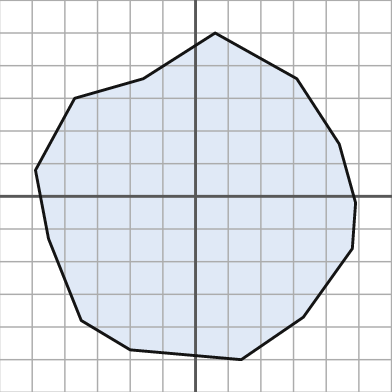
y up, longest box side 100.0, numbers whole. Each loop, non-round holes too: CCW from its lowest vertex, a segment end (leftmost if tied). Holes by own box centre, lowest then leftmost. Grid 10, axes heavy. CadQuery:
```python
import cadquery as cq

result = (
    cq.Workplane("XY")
    .moveTo(14.0, -50.0)
    .lineTo(33.0, -37.0)
    .lineTo(48.0, -16.0)
    .lineTo(49.0, -2.0)
    .lineTo(44.0, 16.0)
    .lineTo(31.0, 36.0)
    .lineTo(6.0, 50.0)
    .lineTo(-16.0, 36.0)
    .lineTo(-37.0, 30.0)
    .lineTo(-49.0, 8.0)
    .lineTo(-45.0, -13.0)
    .lineTo(-35.0, -38.0)
    .lineTo(-20.0, -47.0)
    .close()
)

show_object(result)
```